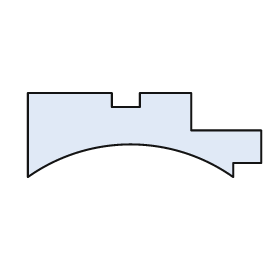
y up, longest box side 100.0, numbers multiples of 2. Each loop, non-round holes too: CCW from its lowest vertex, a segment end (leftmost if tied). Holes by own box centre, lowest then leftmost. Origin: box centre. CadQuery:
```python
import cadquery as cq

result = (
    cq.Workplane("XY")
    .moveTo(-50.0, -18.0)
    .threePointArc((-6.0, -4.0), (38.0, -18.0))
    .lineTo(38.0, -12.0)
    .lineTo(50.0, -12.0)
    .lineTo(50.0, 2.0)
    .lineTo(20.0, 2.0)
    .lineTo(20.0, 18.0)
    .lineTo(-2.0, 18.0)
    .lineTo(-2.0, 12.0)
    .lineTo(-14.0, 12.0)
    .lineTo(-14.0, 18.0)
    .lineTo(-50.0, 18.0)
    .close()
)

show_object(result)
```